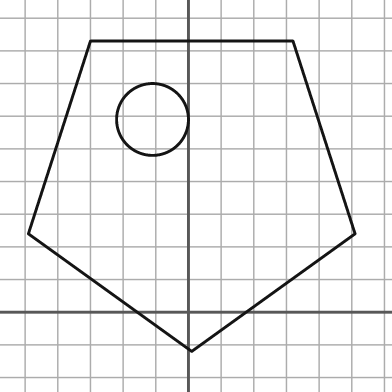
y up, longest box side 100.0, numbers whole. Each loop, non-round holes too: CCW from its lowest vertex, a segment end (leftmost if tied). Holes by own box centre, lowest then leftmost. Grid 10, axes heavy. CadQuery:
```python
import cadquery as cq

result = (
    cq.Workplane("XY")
    .moveTo(1.0, -12.0)
    .lineTo(51.0, 24.0)
    .lineTo(32.0, 83.0)
    .lineTo(-30.0, 83.0)
    .lineTo(-49.0, 24.0)
    .close()
    .moveTo(-11.0, 59.0)
    .circle(11.0)
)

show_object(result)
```